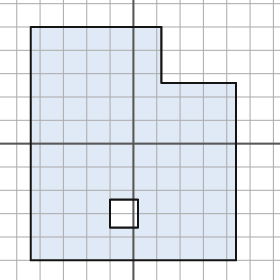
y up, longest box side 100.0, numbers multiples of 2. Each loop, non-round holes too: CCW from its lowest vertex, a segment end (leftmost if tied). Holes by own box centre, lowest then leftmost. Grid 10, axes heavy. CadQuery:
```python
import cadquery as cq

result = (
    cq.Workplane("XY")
    .moveTo(-44.0, -50.0)
    .lineTo(44.0, -50.0)
    .lineTo(44.0, 26.0)
    .lineTo(12.0, 26.0)
    .lineTo(12.0, 50.0)
    .lineTo(-44.0, 50.0)
    .close()
    .moveTo(-10.0, -36.0)
    .lineTo(2.0, -36.0)
    .lineTo(2.0, -24.0)
    .lineTo(-10.0, -24.0)
    .close()
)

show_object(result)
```